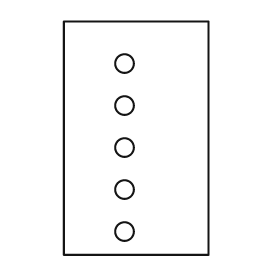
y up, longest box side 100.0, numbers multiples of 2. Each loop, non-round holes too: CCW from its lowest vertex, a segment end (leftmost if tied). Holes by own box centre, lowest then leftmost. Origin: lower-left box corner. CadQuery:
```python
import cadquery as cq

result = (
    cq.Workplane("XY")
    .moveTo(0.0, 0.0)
    .lineTo(62.0, 0.0)
    .lineTo(62.0, 100.0)
    .lineTo(0.0, 100.0)
    .close()
    .moveTo(26.0, 10.0)
    .circle(4.0)
    .moveTo(26.0, 28.0)
    .circle(4.0)
    .moveTo(26.0, 46.0)
    .circle(4.0)
    .moveTo(26.0, 64.0)
    .circle(4.0)
    .moveTo(26.0, 82.0)
    .circle(4.0)
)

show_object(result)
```